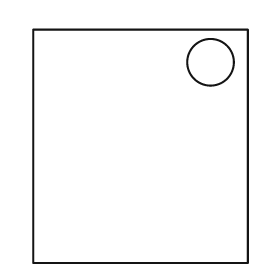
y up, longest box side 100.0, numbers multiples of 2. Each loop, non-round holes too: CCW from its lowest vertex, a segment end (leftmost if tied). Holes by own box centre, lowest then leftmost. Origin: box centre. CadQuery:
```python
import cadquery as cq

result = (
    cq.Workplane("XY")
    .moveTo(-46.0, -50.0)
    .lineTo(46.0, -50.0)
    .lineTo(46.0, 50.0)
    .lineTo(-46.0, 50.0)
    .close()
    .moveTo(30.0, 36.0)
    .circle(10.0)
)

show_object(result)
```